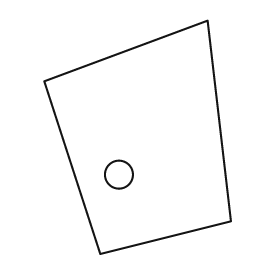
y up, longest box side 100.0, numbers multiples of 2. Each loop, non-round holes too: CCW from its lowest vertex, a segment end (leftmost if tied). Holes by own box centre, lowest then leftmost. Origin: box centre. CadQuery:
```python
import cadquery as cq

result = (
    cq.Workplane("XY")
    .moveTo(-16.0, -50.0)
    .lineTo(40.0, -36.0)
    .lineTo(30.0, 50.0)
    .lineTo(-40.0, 24.0)
    .close()
    .moveTo(-8.0, -16.0)
    .circle(6.0)
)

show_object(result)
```